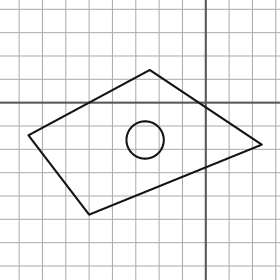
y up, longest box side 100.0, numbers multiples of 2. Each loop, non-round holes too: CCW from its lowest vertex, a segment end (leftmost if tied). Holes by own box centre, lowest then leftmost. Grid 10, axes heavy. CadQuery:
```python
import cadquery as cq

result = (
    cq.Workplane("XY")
    .moveTo(-50.0, -48.0)
    .lineTo(24.0, -18.0)
    .lineTo(-24.0, 14.0)
    .lineTo(-76.0, -14.0)
    .close()
    .moveTo(-26.0, -16.0)
    .circle(8.0)
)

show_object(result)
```